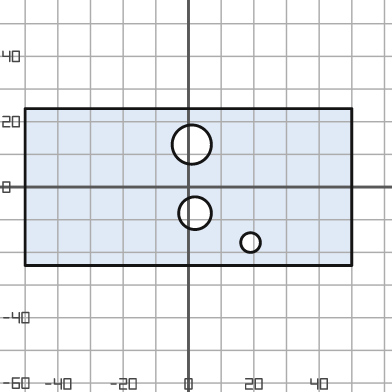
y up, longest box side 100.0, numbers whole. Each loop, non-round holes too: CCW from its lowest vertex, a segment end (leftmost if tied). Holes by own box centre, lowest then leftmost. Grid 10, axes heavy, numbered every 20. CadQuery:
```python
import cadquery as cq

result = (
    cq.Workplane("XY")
    .moveTo(-50.0, -24.0)
    .lineTo(50.0, -24.0)
    .lineTo(50.0, 24.0)
    .lineTo(-50.0, 24.0)
    .close()
    .moveTo(19.0, -17.0)
    .circle(3.0)
    .moveTo(2.0, -8.0)
    .circle(5.0)
    .moveTo(1.0, 13.0)
    .circle(6.0)
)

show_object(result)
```